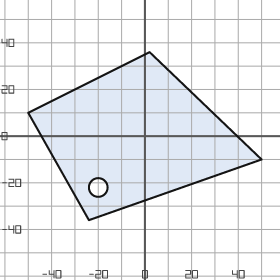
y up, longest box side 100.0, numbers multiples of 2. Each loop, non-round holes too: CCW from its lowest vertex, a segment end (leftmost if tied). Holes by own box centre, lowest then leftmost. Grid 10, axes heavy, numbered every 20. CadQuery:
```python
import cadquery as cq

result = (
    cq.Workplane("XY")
    .moveTo(-24.0, -36.0)
    .lineTo(50.0, -10.0)
    .lineTo(2.0, 36.0)
    .lineTo(-50.0, 10.0)
    .close()
    .moveTo(-20.0, -22.0)
    .circle(4.0)
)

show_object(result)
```